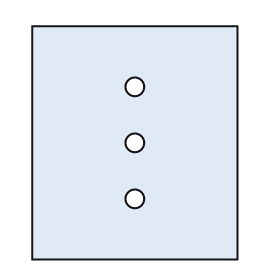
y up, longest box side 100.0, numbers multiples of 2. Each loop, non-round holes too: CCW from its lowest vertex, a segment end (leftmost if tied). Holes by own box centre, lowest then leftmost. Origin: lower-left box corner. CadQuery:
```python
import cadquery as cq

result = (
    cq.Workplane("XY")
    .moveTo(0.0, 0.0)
    .lineTo(88.0, 0.0)
    .lineTo(88.0, 100.0)
    .lineTo(0.0, 100.0)
    .close()
    .moveTo(44.0, 26.0)
    .circle(4.0)
    .moveTo(44.0, 50.0)
    .circle(4.0)
    .moveTo(44.0, 74.0)
    .circle(4.0)
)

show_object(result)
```